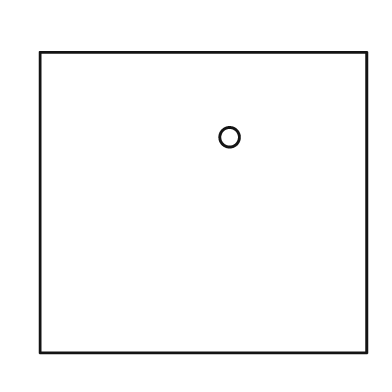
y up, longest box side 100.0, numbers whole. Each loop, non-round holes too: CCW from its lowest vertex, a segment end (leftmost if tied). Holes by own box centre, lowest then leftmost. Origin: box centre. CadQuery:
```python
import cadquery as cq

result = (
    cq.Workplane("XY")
    .moveTo(-50.0, -46.0)
    .lineTo(50.0, -46.0)
    .lineTo(50.0, 46.0)
    .lineTo(-50.0, 46.0)
    .close()
    .moveTo(8.0, 20.0)
    .circle(3.0)
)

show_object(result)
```